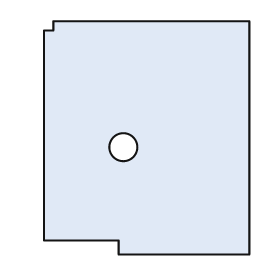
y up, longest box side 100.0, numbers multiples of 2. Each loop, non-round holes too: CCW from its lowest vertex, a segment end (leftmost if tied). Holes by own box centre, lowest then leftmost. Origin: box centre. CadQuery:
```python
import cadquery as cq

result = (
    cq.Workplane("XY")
    .moveTo(-12.0, -50.0)
    .lineTo(44.0, -50.0)
    .lineTo(44.0, 50.0)
    .lineTo(-40.0, 50.0)
    .lineTo(-40.0, 46.0)
    .lineTo(-44.0, 46.0)
    .lineTo(-44.0, -44.0)
    .lineTo(-12.0, -44.0)
    .close()
    .moveTo(-10.0, -4.0)
    .circle(6.0)
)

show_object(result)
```